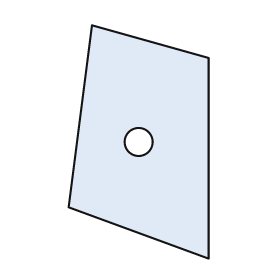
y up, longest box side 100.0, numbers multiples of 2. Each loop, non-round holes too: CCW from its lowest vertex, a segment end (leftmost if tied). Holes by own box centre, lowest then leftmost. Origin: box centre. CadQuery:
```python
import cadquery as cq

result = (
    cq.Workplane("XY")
    .moveTo(30.0, -50.0)
    .lineTo(30.0, 36.0)
    .lineTo(-20.0, 50.0)
    .lineTo(-30.0, -28.0)
    .close()
    .moveTo(0.0, 0.0)
    .circle(6.0)
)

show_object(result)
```